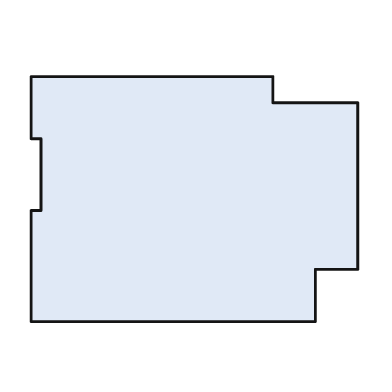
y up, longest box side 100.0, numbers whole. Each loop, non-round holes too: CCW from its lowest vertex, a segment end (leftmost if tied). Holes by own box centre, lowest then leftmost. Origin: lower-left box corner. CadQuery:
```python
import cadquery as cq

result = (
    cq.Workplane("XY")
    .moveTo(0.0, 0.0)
    .lineTo(87.0, 0.0)
    .lineTo(87.0, 16.0)
    .lineTo(100.0, 16.0)
    .lineTo(100.0, 67.0)
    .lineTo(74.0, 67.0)
    .lineTo(74.0, 75.0)
    .lineTo(0.0, 75.0)
    .lineTo(0.0, 56.0)
    .lineTo(3.0, 56.0)
    .lineTo(3.0, 34.0)
    .lineTo(0.0, 34.0)
    .close()
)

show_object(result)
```